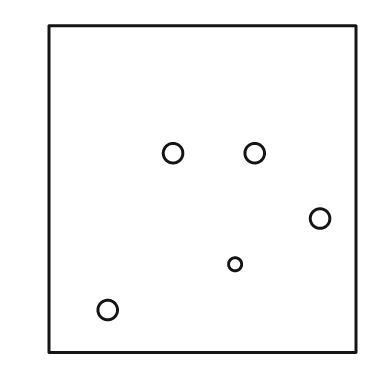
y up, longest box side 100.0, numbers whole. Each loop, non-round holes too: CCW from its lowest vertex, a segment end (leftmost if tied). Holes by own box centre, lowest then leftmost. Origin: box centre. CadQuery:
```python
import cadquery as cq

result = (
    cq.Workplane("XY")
    .moveTo(-47.0, -50.0)
    .lineTo(47.0, -50.0)
    .lineTo(47.0, 50.0)
    .lineTo(-47.0, 50.0)
    .close()
    .moveTo(-29.0, -37.0)
    .circle(3.0)
    .moveTo(10.0, -23.0)
    .circle(2.0)
    .moveTo(36.0, -9.0)
    .circle(3.0)
    .moveTo(-9.0, 11.0)
    .circle(3.0)
    .moveTo(16.0, 11.0)
    .circle(3.0)
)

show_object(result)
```